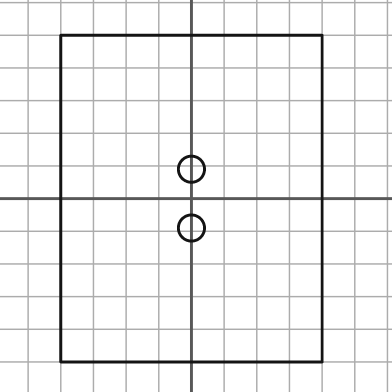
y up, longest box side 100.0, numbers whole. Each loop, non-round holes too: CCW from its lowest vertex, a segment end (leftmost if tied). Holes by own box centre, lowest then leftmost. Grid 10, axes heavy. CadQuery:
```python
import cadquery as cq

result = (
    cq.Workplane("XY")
    .moveTo(-40.0, -50.0)
    .lineTo(40.0, -50.0)
    .lineTo(40.0, 50.0)
    .lineTo(-40.0, 50.0)
    .close()
    .moveTo(0.0, -9.0)
    .circle(4.0)
    .moveTo(0.0, 9.0)
    .circle(4.0)
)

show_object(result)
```